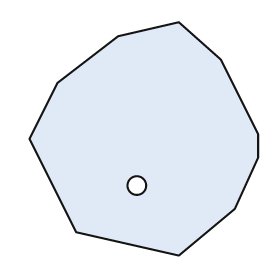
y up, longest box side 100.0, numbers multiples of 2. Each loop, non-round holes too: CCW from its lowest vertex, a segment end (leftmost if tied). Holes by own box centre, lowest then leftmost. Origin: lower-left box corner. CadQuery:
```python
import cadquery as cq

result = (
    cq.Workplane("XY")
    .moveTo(64.0, 0.0)
    .lineTo(88.0, 20.0)
    .lineTo(98.0, 42.0)
    .lineTo(98.0, 52.0)
    .lineTo(82.0, 84.0)
    .lineTo(64.0, 100.0)
    .lineTo(38.0, 94.0)
    .lineTo(12.0, 74.0)
    .lineTo(0.0, 50.0)
    .lineTo(20.0, 10.0)
    .close()
    .moveTo(46.0, 30.0)
    .circle(4.0)
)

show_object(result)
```